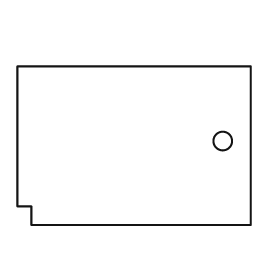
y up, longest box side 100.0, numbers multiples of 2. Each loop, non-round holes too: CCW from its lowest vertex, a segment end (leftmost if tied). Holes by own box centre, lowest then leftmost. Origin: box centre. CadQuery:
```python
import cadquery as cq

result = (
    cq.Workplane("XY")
    .moveTo(-44.0, -34.0)
    .lineTo(50.0, -34.0)
    .lineTo(50.0, 34.0)
    .lineTo(-50.0, 34.0)
    .lineTo(-50.0, -26.0)
    .lineTo(-44.0, -26.0)
    .close()
    .moveTo(38.0, 2.0)
    .circle(4.0)
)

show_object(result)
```